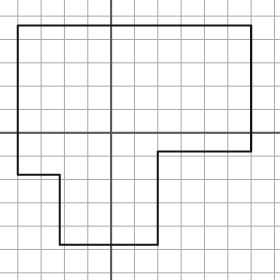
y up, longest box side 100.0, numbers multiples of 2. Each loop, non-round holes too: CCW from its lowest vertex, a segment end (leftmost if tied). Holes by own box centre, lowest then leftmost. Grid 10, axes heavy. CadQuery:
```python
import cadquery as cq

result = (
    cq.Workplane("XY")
    .moveTo(-22.0, -48.0)
    .lineTo(20.0, -48.0)
    .lineTo(20.0, -8.0)
    .lineTo(60.0, -8.0)
    .lineTo(60.0, 46.0)
    .lineTo(-40.0, 46.0)
    .lineTo(-40.0, -18.0)
    .lineTo(-22.0, -18.0)
    .close()
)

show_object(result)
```